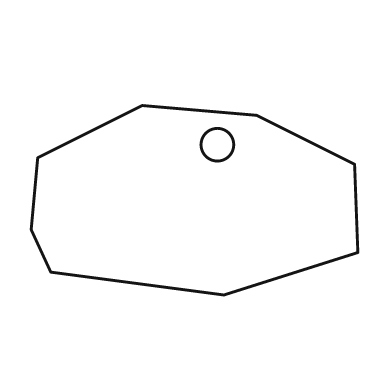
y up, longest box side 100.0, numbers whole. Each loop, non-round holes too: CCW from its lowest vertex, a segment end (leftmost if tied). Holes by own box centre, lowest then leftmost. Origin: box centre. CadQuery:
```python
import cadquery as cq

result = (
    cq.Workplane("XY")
    .moveTo(9.0, -29.0)
    .lineTo(50.0, -16.0)
    .lineTo(49.0, 11.0)
    .lineTo(19.0, 26.0)
    .lineTo(-16.0, 29.0)
    .lineTo(-48.0, 13.0)
    .lineTo(-50.0, -9.0)
    .lineTo(-44.0, -22.0)
    .close()
    .moveTo(7.0, 17.0)
    .circle(5.0)
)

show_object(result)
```